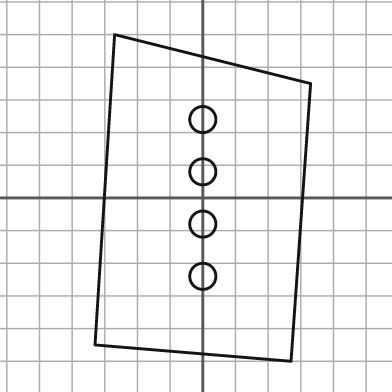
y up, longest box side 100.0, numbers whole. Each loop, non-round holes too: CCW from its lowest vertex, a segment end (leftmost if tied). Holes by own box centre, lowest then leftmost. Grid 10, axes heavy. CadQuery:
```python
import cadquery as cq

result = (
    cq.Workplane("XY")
    .moveTo(27.0, -50.0)
    .lineTo(33.0, 35.0)
    .lineTo(-27.0, 50.0)
    .lineTo(-33.0, -45.0)
    .close()
    .moveTo(0.0, -24.0)
    .circle(4.0)
    .moveTo(0.0, -8.0)
    .circle(4.0)
    .moveTo(0.0, 8.0)
    .circle(4.0)
    .moveTo(0.0, 24.0)
    .circle(4.0)
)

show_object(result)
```